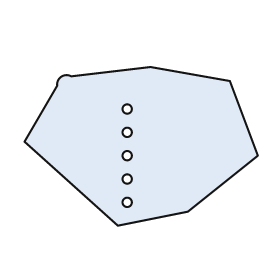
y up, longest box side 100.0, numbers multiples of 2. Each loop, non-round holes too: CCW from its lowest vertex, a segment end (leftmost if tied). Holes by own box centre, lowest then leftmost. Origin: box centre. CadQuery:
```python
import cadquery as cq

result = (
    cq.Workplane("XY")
    .moveTo(-10.0, -34.0)
    .lineTo(20.0, -28.0)
    .lineTo(50.0, -4.0)
    .lineTo(38.0, 28.0)
    .lineTo(4.0, 34.0)
    .lineTo(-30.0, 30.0)
    .threePointArc((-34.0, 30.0), (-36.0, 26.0))
    .lineTo(-50.0, 2.0)
    .close()
    .moveTo(-6.0, -24.0)
    .circle(2.0)
    .moveTo(-6.0, -14.0)
    .circle(2.0)
    .moveTo(-6.0, -4.0)
    .circle(2.0)
    .moveTo(-6.0, 6.0)
    .circle(2.0)
    .moveTo(-6.0, 16.0)
    .circle(2.0)
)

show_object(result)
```